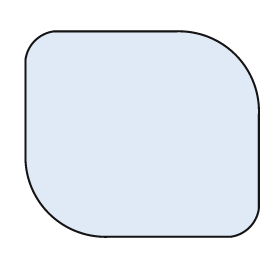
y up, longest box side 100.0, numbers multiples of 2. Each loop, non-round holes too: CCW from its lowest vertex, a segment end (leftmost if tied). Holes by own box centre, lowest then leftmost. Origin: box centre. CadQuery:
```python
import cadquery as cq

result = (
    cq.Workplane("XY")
    .moveTo(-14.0, -44.0)
    .lineTo(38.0, -44.0)
    .threePointArc((46.0, -40.0), (50.0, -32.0))
    .lineTo(50.0, 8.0)
    .threePointArc((40.0, 34.0), (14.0, 44.0))
    .lineTo(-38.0, 44.0)
    .threePointArc((-46.0, 40.0), (-50.0, 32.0))
    .lineTo(-50.0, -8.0)
    .threePointArc((-40.0, -34.0), (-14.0, -44.0))
    .close()
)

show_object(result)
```